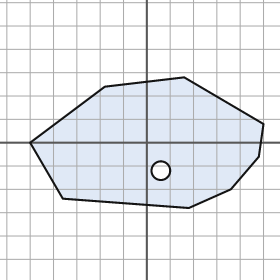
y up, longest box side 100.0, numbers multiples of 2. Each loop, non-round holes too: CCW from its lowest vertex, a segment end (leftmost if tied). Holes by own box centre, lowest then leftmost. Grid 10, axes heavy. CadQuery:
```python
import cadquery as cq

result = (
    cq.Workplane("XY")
    .moveTo(18.0, -28.0)
    .lineTo(36.0, -20.0)
    .lineTo(48.0, -6.0)
    .lineTo(50.0, 8.0)
    .lineTo(16.0, 28.0)
    .lineTo(-18.0, 24.0)
    .lineTo(-50.0, 0.0)
    .lineTo(-36.0, -24.0)
    .close()
    .moveTo(6.0, -12.0)
    .circle(4.0)
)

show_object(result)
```